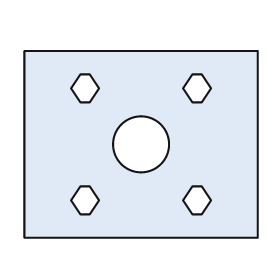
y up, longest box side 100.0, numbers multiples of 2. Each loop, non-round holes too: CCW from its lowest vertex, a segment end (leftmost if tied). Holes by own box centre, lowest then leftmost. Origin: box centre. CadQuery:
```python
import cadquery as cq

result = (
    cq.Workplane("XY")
    .moveTo(-50.0, -40.0)
    .lineTo(50.0, -40.0)
    .lineTo(50.0, 40.0)
    .lineTo(-50.0, 40.0)
    .close()
    .moveTo(-26.0, -30.0)
    .lineTo(-22.0, -30.0)
    .lineTo(-18.0, -24.0)
    .lineTo(-22.0, -18.0)
    .lineTo(-26.0, -18.0)
    .lineTo(-30.0, -24.0)
    .close()
    .moveTo(22.0, -30.0)
    .lineTo(26.0, -30.0)
    .lineTo(30.0, -24.0)
    .lineTo(26.0, -18.0)
    .lineTo(22.0, -18.0)
    .lineTo(18.0, -24.0)
    .close()
    .moveTo(0.0, 0.0)
    .circle(12.0)
    .moveTo(-26.0, 18.0)
    .lineTo(-22.0, 18.0)
    .lineTo(-18.0, 24.0)
    .lineTo(-22.0, 30.0)
    .lineTo(-26.0, 30.0)
    .lineTo(-30.0, 24.0)
    .close()
    .moveTo(22.0, 18.0)
    .lineTo(26.0, 18.0)
    .lineTo(30.0, 24.0)
    .lineTo(26.0, 30.0)
    .lineTo(22.0, 30.0)
    .lineTo(18.0, 24.0)
    .close()
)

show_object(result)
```